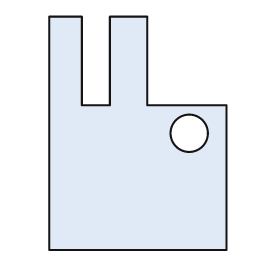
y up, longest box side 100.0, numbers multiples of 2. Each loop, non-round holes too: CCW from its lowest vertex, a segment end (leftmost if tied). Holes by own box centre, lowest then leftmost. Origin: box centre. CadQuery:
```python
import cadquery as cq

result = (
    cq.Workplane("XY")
    .moveTo(-38.0, -50.0)
    .lineTo(38.0, -50.0)
    .lineTo(38.0, 12.0)
    .lineTo(4.0, 12.0)
    .lineTo(4.0, 50.0)
    .lineTo(-12.0, 50.0)
    .lineTo(-12.0, 12.0)
    .lineTo(-24.0, 12.0)
    .lineTo(-24.0, 50.0)
    .lineTo(-38.0, 50.0)
    .close()
    .moveTo(22.0, 0.0)
    .circle(8.0)
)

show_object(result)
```